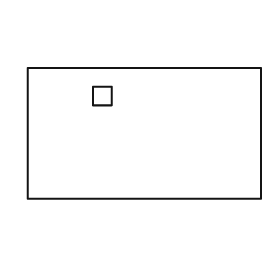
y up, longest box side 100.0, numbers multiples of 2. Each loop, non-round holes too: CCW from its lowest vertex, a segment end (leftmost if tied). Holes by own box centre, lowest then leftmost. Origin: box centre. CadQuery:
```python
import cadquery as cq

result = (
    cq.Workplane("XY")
    .moveTo(-50.0, -28.0)
    .lineTo(50.0, -28.0)
    .lineTo(50.0, 28.0)
    .lineTo(-50.0, 28.0)
    .close()
    .moveTo(-22.0, 12.0)
    .lineTo(-14.0, 12.0)
    .lineTo(-14.0, 20.0)
    .lineTo(-22.0, 20.0)
    .close()
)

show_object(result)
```